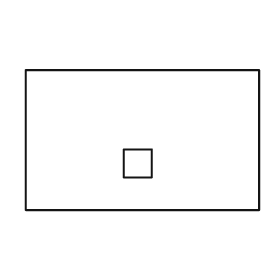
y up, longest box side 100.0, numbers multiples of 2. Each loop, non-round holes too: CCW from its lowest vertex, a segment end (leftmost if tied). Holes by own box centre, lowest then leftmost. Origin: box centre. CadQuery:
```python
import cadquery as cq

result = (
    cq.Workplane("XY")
    .moveTo(-50.0, -30.0)
    .lineTo(50.0, -30.0)
    .lineTo(50.0, 30.0)
    .lineTo(-50.0, 30.0)
    .close()
    .moveTo(-8.0, -16.0)
    .lineTo(4.0, -16.0)
    .lineTo(4.0, -4.0)
    .lineTo(-8.0, -4.0)
    .close()
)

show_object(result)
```